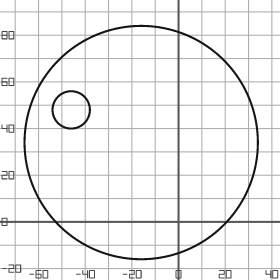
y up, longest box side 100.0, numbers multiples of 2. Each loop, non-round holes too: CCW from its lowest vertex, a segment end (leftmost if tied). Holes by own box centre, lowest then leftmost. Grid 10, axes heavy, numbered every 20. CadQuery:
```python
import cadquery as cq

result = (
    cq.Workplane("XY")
    .moveTo(-16.0, 34.0)
    .circle(50.0)
    .moveTo(-46.0, 48.0)
    .circle(8.0)
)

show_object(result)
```